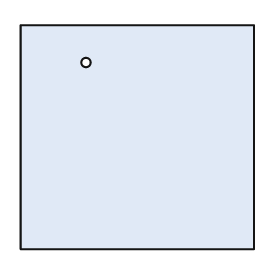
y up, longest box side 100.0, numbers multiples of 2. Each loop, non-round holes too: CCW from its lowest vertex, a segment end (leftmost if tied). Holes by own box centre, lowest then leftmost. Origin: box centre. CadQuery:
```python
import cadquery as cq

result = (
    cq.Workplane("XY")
    .moveTo(-50.0, -48.0)
    .lineTo(50.0, -48.0)
    .lineTo(50.0, 48.0)
    .lineTo(-50.0, 48.0)
    .close()
    .moveTo(-22.0, 32.0)
    .circle(2.0)
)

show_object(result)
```